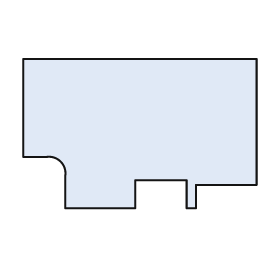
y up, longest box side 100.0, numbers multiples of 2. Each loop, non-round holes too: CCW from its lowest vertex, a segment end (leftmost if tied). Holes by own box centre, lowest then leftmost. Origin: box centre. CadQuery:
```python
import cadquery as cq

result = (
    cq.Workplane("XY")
    .moveTo(-32.0, -32.0)
    .lineTo(-2.0, -32.0)
    .lineTo(-2.0, -20.0)
    .lineTo(20.0, -20.0)
    .lineTo(20.0, -32.0)
    .lineTo(24.0, -32.0)
    .lineTo(24.0, -22.0)
    .lineTo(50.0, -22.0)
    .lineTo(50.0, 32.0)
    .lineTo(-50.0, 32.0)
    .lineTo(-50.0, -10.0)
    .lineTo(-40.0, -10.0)
    .threePointArc((-34.0, -12.0), (-32.0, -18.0))
    .close()
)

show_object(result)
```